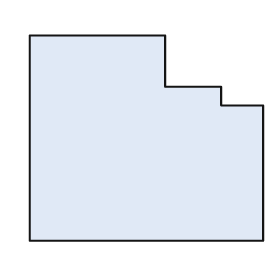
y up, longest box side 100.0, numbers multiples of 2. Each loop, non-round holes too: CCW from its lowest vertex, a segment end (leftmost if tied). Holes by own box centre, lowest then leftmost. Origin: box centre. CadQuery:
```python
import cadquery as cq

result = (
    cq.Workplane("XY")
    .moveTo(-50.0, -44.0)
    .lineTo(50.0, -44.0)
    .lineTo(50.0, 14.0)
    .lineTo(32.0, 14.0)
    .lineTo(32.0, 22.0)
    .lineTo(8.0, 22.0)
    .lineTo(8.0, 44.0)
    .lineTo(-50.0, 44.0)
    .close()
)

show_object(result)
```